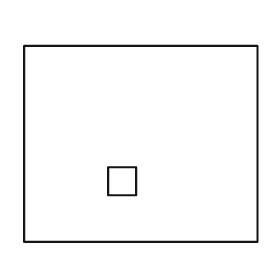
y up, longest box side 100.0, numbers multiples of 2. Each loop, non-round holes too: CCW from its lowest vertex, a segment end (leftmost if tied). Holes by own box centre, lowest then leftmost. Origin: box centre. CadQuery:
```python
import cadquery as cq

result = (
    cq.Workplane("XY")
    .moveTo(-50.0, -42.0)
    .lineTo(50.0, -42.0)
    .lineTo(50.0, 42.0)
    .lineTo(-50.0, 42.0)
    .close()
    .moveTo(-14.0, -22.0)
    .lineTo(-2.0, -22.0)
    .lineTo(-2.0, -10.0)
    .lineTo(-14.0, -10.0)
    .close()
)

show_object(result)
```